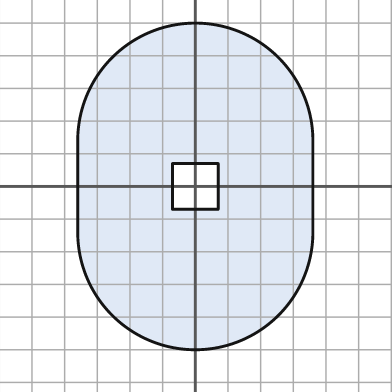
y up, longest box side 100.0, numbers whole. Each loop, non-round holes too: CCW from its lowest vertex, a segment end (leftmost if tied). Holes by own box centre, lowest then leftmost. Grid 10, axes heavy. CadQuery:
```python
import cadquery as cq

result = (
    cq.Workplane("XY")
    .moveTo(-36.0, -14.0)
    .threePointArc((0.0, -50.0), (36.0, -14.0))
    .lineTo(36.0, 14.0)
    .threePointArc((0.0, 50.0), (-36.0, 14.0))
    .close()
    .moveTo(-7.0, -7.0)
    .lineTo(7.0, -7.0)
    .lineTo(7.0, 7.0)
    .lineTo(-7.0, 7.0)
    .close()
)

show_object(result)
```